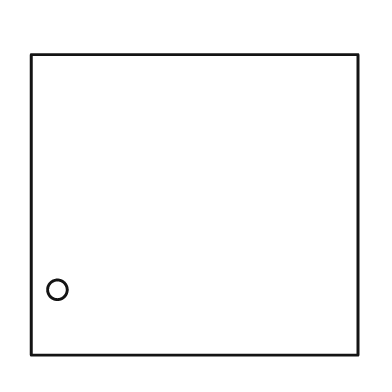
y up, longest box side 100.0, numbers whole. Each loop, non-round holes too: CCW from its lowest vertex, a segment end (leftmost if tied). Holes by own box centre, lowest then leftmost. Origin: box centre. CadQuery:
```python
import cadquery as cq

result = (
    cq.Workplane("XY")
    .moveTo(-50.0, -46.0)
    .lineTo(50.0, -46.0)
    .lineTo(50.0, 46.0)
    .lineTo(-50.0, 46.0)
    .close()
    .moveTo(-42.0, -26.0)
    .circle(3.0)
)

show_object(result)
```